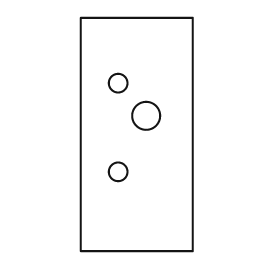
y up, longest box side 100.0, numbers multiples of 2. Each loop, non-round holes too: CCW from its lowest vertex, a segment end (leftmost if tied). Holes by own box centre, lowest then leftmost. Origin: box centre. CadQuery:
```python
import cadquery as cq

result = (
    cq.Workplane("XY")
    .moveTo(-24.0, -50.0)
    .lineTo(24.0, -50.0)
    .lineTo(24.0, 50.0)
    .lineTo(-24.0, 50.0)
    .close()
    .moveTo(-8.0, -16.0)
    .circle(4.0)
    .moveTo(4.0, 8.0)
    .circle(6.0)
    .moveTo(-8.0, 22.0)
    .circle(4.0)
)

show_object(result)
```